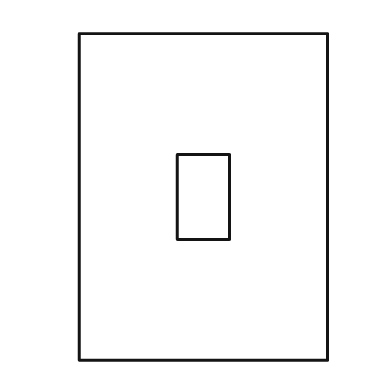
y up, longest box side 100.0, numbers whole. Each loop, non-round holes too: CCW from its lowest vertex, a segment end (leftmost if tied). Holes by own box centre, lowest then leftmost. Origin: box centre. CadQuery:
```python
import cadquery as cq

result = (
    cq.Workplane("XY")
    .moveTo(-38.0, -50.0)
    .lineTo(38.0, -50.0)
    .lineTo(38.0, 50.0)
    .lineTo(-38.0, 50.0)
    .close()
    .moveTo(-8.0, -13.0)
    .lineTo(8.0, -13.0)
    .lineTo(8.0, 13.0)
    .lineTo(-8.0, 13.0)
    .close()
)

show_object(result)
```